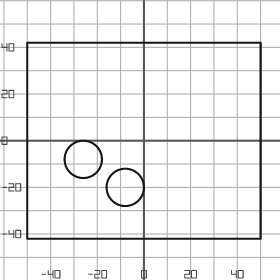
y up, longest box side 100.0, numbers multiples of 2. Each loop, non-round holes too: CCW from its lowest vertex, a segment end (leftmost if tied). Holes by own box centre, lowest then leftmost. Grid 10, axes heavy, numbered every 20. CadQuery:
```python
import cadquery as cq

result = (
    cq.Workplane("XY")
    .moveTo(-50.0, -42.0)
    .lineTo(50.0, -42.0)
    .lineTo(50.0, 42.0)
    .lineTo(-50.0, 42.0)
    .close()
    .moveTo(-8.0, -20.0)
    .circle(8.0)
    .moveTo(-26.0, -8.0)
    .circle(8.0)
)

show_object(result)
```